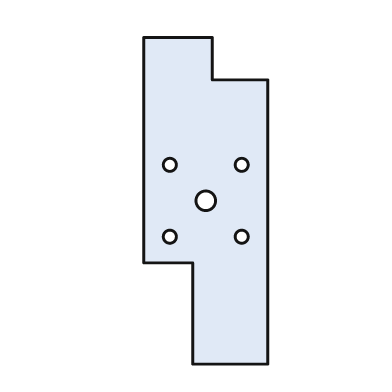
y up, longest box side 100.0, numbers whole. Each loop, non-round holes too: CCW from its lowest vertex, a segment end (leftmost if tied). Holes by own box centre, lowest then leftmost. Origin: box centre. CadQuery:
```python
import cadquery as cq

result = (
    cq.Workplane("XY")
    .moveTo(-4.0, -50.0)
    .lineTo(19.0, -50.0)
    .lineTo(19.0, 37.0)
    .lineTo(2.0, 37.0)
    .lineTo(2.0, 50.0)
    .lineTo(-19.0, 50.0)
    .lineTo(-19.0, -19.0)
    .lineTo(-4.0, -19.0)
    .close()
    .moveTo(-11.0, -11.0)
    .circle(2.0)
    .moveTo(11.0, -11.0)
    .circle(2.0)
    .moveTo(0.0, 0.0)
    .circle(3.0)
    .moveTo(-11.0, 11.0)
    .circle(2.0)
    .moveTo(11.0, 11.0)
    .circle(2.0)
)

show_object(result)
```